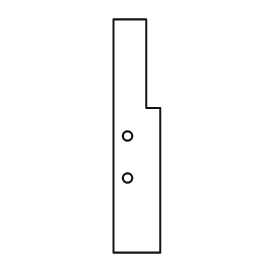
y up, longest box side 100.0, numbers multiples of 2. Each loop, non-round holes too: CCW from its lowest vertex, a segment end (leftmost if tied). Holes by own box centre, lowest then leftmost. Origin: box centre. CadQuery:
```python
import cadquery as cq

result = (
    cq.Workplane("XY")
    .moveTo(-10.0, -50.0)
    .lineTo(10.0, -50.0)
    .lineTo(10.0, 12.0)
    .lineTo(4.0, 12.0)
    .lineTo(4.0, 50.0)
    .lineTo(-10.0, 50.0)
    .close()
    .moveTo(-4.0, -18.0)
    .circle(2.0)
    .moveTo(-4.0, 0.0)
    .circle(2.0)
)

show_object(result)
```